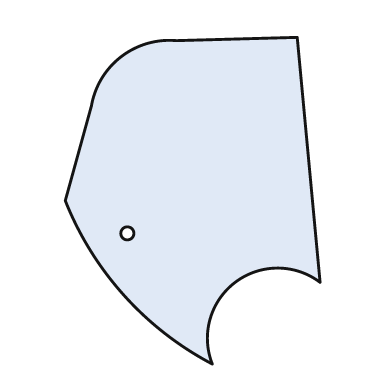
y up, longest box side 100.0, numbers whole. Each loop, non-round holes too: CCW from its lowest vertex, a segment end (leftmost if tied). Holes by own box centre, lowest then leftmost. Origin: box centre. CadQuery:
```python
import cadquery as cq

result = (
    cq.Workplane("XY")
    .moveTo(6.0, -50.0)
    .threePointArc((13.0, -25.0), (39.0, -25.0))
    .lineTo(32.0, 50.0)
    .lineTo(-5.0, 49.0)
    .threePointArc((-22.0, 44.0), (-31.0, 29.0))
    .lineTo(-39.0, 0.0)
    .threePointArc((-21.0, -29.0), (6.0, -50.0))
    .close()
    .moveTo(-20.0, -10.0)
    .circle(2.0)
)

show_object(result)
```